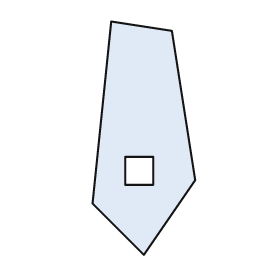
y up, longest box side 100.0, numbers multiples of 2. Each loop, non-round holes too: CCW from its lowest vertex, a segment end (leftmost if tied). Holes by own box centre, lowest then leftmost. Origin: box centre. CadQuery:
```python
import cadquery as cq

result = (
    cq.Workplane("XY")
    .moveTo(0.0, -50.0)
    .lineTo(22.0, -18.0)
    .lineTo(12.0, 46.0)
    .lineTo(-14.0, 50.0)
    .lineTo(-22.0, -28.0)
    .close()
    .moveTo(-8.0, -20.0)
    .lineTo(4.0, -20.0)
    .lineTo(4.0, -8.0)
    .lineTo(-8.0, -8.0)
    .close()
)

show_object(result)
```